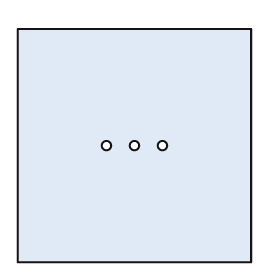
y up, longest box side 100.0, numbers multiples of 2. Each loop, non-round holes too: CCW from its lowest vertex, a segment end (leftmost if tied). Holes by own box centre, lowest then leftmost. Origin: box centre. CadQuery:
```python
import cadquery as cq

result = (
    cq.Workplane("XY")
    .moveTo(-50.0, -50.0)
    .lineTo(50.0, -50.0)
    .lineTo(50.0, 50.0)
    .lineTo(-50.0, 50.0)
    .close()
    .moveTo(-12.0, 0.0)
    .circle(2.0)
    .moveTo(0.0, 0.0)
    .circle(2.0)
    .moveTo(12.0, 0.0)
    .circle(2.0)
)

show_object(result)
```